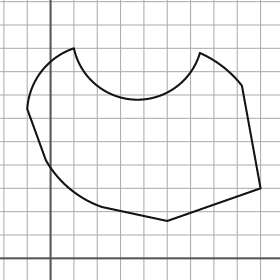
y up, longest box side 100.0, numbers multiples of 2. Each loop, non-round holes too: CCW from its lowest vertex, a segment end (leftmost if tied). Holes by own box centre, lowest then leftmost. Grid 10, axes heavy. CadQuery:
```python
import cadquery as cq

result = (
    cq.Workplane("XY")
    .moveTo(50.0, 16.0)
    .lineTo(90.0, 30.0)
    .lineTo(82.0, 74.0)
    .threePointArc((74.0, 82.0), (64.0, 88.0))
    .threePointArc((36.0, 68.0), (10.0, 90.0))
    .threePointArc((-4.0, 80.0), (-10.0, 64.0))
    .lineTo(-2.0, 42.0)
    .threePointArc((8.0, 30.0), (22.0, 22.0))
    .close()
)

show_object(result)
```